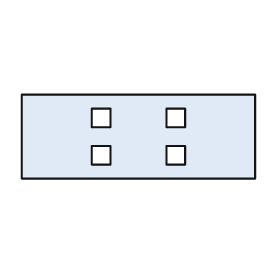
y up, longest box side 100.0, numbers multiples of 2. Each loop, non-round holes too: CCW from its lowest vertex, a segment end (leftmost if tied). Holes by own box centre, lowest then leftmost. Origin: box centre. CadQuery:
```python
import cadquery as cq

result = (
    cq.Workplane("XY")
    .moveTo(-50.0, -18.0)
    .lineTo(50.0, -18.0)
    .lineTo(50.0, 18.0)
    .lineTo(-50.0, 18.0)
    .close()
    .moveTo(-20.0, -12.0)
    .lineTo(-12.0, -12.0)
    .lineTo(-12.0, -4.0)
    .lineTo(-20.0, -4.0)
    .close()
    .moveTo(12.0, -12.0)
    .lineTo(20.0, -12.0)
    .lineTo(20.0, -4.0)
    .lineTo(12.0, -4.0)
    .close()
    .moveTo(-20.0, 4.0)
    .lineTo(-12.0, 4.0)
    .lineTo(-12.0, 12.0)
    .lineTo(-20.0, 12.0)
    .close()
    .moveTo(12.0, 4.0)
    .lineTo(20.0, 4.0)
    .lineTo(20.0, 12.0)
    .lineTo(12.0, 12.0)
    .close()
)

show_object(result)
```